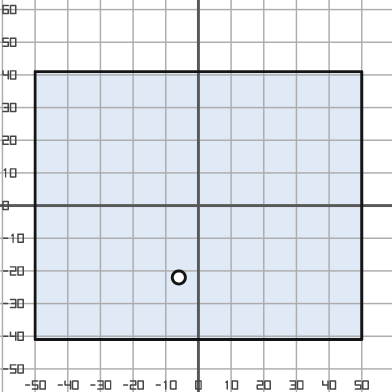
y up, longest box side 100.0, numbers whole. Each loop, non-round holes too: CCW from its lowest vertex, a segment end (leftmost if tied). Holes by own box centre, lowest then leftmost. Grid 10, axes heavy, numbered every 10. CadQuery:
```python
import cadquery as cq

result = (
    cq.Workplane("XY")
    .moveTo(-50.0, -41.0)
    .lineTo(50.0, -41.0)
    .lineTo(50.0, 41.0)
    .lineTo(-50.0, 41.0)
    .close()
    .moveTo(-6.0, -22.0)
    .circle(2.0)
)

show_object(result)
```